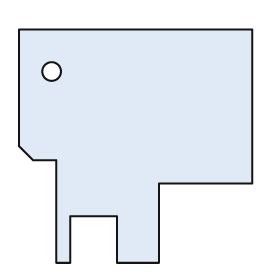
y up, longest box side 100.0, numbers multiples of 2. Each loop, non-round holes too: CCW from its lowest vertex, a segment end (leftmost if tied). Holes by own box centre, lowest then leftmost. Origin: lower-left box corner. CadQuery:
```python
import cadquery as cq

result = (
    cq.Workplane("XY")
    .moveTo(16.0, 0.0)
    .lineTo(22.0, 0.0)
    .lineTo(22.0, 20.0)
    .lineTo(42.0, 20.0)
    .lineTo(42.0, 0.0)
    .lineTo(60.0, 0.0)
    .lineTo(60.0, 34.0)
    .lineTo(100.0, 34.0)
    .lineTo(100.0, 100.0)
    .lineTo(0.0, 100.0)
    .lineTo(0.0, 50.0)
    .lineTo(6.0, 44.0)
    .lineTo(16.0, 44.0)
    .close()
    .moveTo(14.0, 82.0)
    .circle(4.0)
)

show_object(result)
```